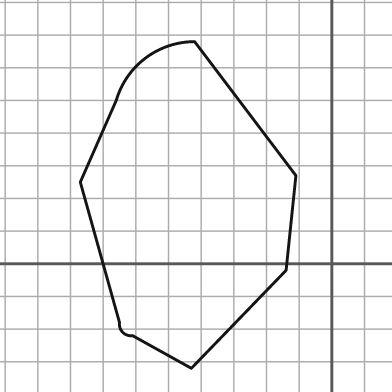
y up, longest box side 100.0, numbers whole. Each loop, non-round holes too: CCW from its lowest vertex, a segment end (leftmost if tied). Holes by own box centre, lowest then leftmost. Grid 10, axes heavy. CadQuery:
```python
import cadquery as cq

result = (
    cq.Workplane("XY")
    .moveTo(-43.0, -32.0)
    .lineTo(-14.0, -2.0)
    .lineTo(-11.0, 27.0)
    .lineTo(-42.0, 68.0)
    .threePointArc((-57.0, 63.0), (-66.0, 50.0))
    .lineTo(-77.0, 25.0)
    .lineTo(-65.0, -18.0)
    .threePointArc((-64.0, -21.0), (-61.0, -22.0))
    .close()
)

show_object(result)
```